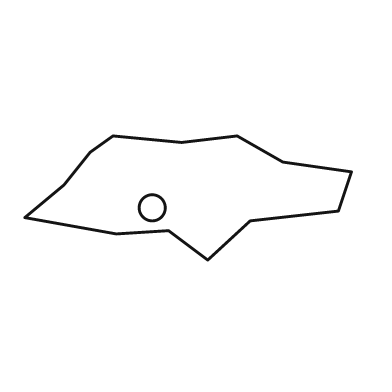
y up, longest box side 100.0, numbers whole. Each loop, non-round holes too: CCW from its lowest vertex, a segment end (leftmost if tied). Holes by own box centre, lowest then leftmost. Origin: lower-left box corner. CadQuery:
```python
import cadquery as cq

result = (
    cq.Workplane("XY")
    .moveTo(56.0, 0.0)
    .lineTo(69.0, 12.0)
    .lineTo(96.0, 15.0)
    .lineTo(100.0, 27.0)
    .lineTo(79.0, 30.0)
    .lineTo(65.0, 38.0)
    .lineTo(48.0, 36.0)
    .lineTo(27.0, 38.0)
    .lineTo(20.0, 33.0)
    .lineTo(12.0, 23.0)
    .lineTo(0.0, 13.0)
    .lineTo(28.0, 8.0)
    .lineTo(44.0, 9.0)
    .close()
    .moveTo(39.0, 16.0)
    .circle(4.0)
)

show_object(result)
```